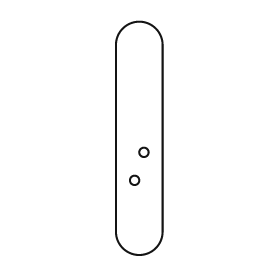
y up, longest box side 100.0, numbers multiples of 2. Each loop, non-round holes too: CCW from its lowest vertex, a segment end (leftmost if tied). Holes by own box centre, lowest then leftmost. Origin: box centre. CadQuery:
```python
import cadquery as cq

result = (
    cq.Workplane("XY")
    .moveTo(-10.0, -40.0)
    .threePointArc((0.0, -50.0), (10.0, -40.0))
    .lineTo(10.0, 40.0)
    .threePointArc((0.0, 50.0), (-10.0, 40.0))
    .close()
    .moveTo(-2.0, -18.0)
    .circle(2.0)
    .moveTo(2.0, -6.0)
    .circle(2.0)
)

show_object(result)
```